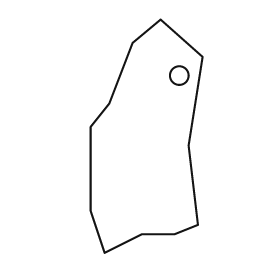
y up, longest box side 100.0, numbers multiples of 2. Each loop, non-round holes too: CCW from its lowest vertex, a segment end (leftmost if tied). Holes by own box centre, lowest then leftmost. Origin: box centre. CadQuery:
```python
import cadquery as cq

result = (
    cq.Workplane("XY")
    .moveTo(-18.0, -50.0)
    .lineTo(-2.0, -42.0)
    .lineTo(12.0, -42.0)
    .lineTo(22.0, -38.0)
    .lineTo(18.0, -4.0)
    .lineTo(24.0, 34.0)
    .lineTo(6.0, 50.0)
    .lineTo(-6.0, 40.0)
    .lineTo(-16.0, 14.0)
    .lineTo(-24.0, 4.0)
    .lineTo(-24.0, -32.0)
    .close()
    .moveTo(14.0, 26.0)
    .circle(4.0)
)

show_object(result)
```